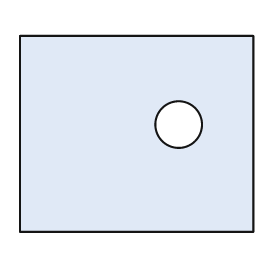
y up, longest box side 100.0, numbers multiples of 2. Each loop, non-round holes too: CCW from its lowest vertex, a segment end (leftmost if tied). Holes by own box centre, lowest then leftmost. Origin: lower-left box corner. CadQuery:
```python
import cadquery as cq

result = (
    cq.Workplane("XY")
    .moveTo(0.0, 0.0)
    .lineTo(100.0, 0.0)
    .lineTo(100.0, 84.0)
    .lineTo(0.0, 84.0)
    .close()
    .moveTo(68.0, 46.0)
    .circle(10.0)
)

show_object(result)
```